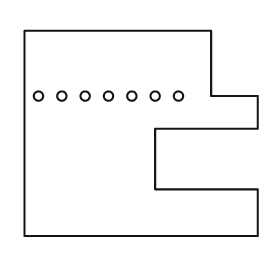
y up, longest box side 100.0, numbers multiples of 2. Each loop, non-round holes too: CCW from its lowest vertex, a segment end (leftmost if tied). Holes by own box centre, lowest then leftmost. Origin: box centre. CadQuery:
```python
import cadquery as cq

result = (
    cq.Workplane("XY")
    .moveTo(-50.0, -44.0)
    .lineTo(50.0, -44.0)
    .lineTo(50.0, -24.0)
    .lineTo(6.0, -24.0)
    .lineTo(6.0, 2.0)
    .lineTo(50.0, 2.0)
    .lineTo(50.0, 16.0)
    .lineTo(30.0, 16.0)
    .lineTo(30.0, 44.0)
    .lineTo(-50.0, 44.0)
    .close()
    .moveTo(-44.0, 16.0)
    .circle(2.0)
    .moveTo(-34.0, 16.0)
    .circle(2.0)
    .moveTo(-24.0, 16.0)
    .circle(2.0)
    .moveTo(-14.0, 16.0)
    .circle(2.0)
    .moveTo(-4.0, 16.0)
    .circle(2.0)
    .moveTo(6.0, 16.0)
    .circle(2.0)
    .moveTo(16.0, 16.0)
    .circle(2.0)
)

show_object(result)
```